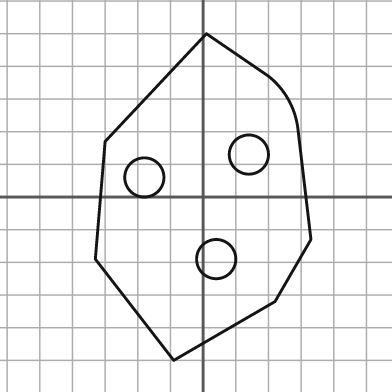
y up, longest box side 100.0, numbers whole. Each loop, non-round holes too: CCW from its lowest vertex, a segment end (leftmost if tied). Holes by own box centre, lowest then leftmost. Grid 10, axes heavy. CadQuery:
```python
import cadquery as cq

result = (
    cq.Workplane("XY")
    .moveTo(-9.0, -50.0)
    .lineTo(22.0, -32.0)
    .lineTo(33.0, -13.0)
    .lineTo(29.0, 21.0)
    .threePointArc((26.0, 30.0), (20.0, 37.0))
    .lineTo(1.0, 50.0)
    .lineTo(-30.0, 17.0)
    .lineTo(-33.0, -19.0)
    .close()
    .moveTo(4.0, -19.0)
    .circle(6.0)
    .moveTo(-18.0, 6.0)
    .circle(6.0)
    .moveTo(14.0, 13.0)
    .circle(6.0)
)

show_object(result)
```